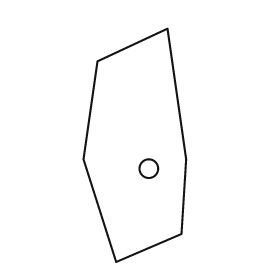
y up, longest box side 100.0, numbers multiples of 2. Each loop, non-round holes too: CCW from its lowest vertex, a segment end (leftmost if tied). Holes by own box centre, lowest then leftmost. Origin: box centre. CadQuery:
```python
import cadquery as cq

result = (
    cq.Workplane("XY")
    .moveTo(-8.0, -50.0)
    .lineTo(20.0, -38.0)
    .lineTo(22.0, -6.0)
    .lineTo(14.0, 50.0)
    .lineTo(-16.0, 36.0)
    .lineTo(-22.0, -6.0)
    .close()
    .moveTo(6.0, -10.0)
    .circle(4.0)
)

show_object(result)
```